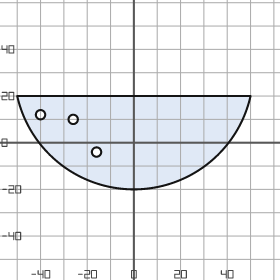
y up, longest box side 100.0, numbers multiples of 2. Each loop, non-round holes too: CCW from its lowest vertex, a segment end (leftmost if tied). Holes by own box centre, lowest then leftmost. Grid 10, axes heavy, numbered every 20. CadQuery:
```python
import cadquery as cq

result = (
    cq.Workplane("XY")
    .moveTo(-50.0, 20.0)
    .threePointArc((0.0, -20.0), (50.0, 20.0))
    .close()
    .moveTo(-16.0, -4.0)
    .circle(2.0)
    .moveTo(-26.0, 10.0)
    .circle(2.0)
    .moveTo(-40.0, 12.0)
    .circle(2.0)
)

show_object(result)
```